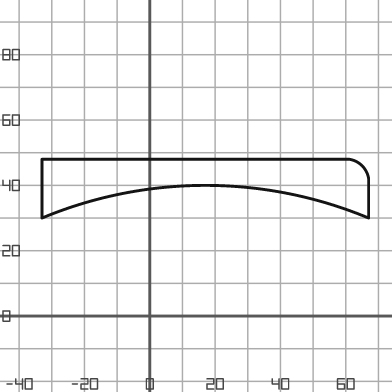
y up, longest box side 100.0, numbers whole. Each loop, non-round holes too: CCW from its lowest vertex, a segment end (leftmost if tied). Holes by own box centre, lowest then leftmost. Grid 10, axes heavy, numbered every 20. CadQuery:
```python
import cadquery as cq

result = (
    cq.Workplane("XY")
    .moveTo(-33.0, 30.0)
    .threePointArc((17.0, 40.0), (67.0, 30.0))
    .lineTo(67.0, 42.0)
    .threePointArc((65.0, 46.0), (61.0, 48.0))
    .lineTo(-33.0, 48.0)
    .close()
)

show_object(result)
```